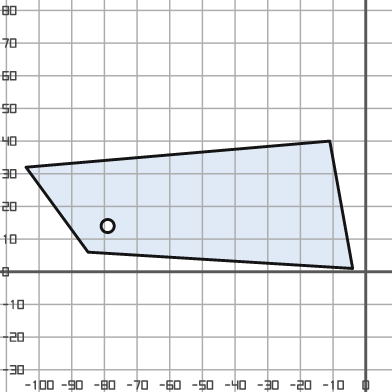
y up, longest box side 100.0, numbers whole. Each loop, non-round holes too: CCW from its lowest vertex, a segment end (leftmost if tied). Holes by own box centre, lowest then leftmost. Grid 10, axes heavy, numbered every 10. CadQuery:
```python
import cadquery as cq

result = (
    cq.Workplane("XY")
    .moveTo(-4.0, 1.0)
    .lineTo(-11.0, 40.0)
    .lineTo(-104.0, 32.0)
    .lineTo(-85.0, 6.0)
    .close()
    .moveTo(-79.0, 14.0)
    .circle(2.0)
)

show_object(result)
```